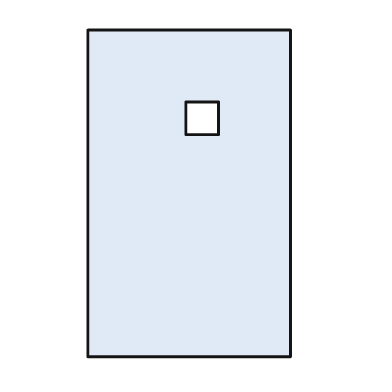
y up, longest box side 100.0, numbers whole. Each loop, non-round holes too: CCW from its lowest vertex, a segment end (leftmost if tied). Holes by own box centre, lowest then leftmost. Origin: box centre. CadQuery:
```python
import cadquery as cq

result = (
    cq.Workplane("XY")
    .moveTo(-31.0, -50.0)
    .lineTo(31.0, -50.0)
    .lineTo(31.0, 50.0)
    .lineTo(-31.0, 50.0)
    .close()
    .moveTo(-1.0, 18.0)
    .lineTo(9.0, 18.0)
    .lineTo(9.0, 28.0)
    .lineTo(-1.0, 28.0)
    .close()
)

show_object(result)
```